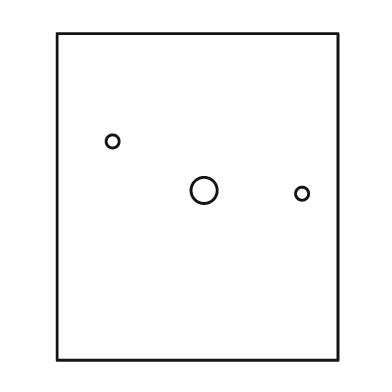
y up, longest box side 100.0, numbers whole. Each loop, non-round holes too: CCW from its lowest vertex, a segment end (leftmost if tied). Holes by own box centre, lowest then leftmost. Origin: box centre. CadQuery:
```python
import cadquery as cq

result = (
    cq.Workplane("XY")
    .moveTo(-43.0, -50.0)
    .lineTo(43.0, -50.0)
    .lineTo(43.0, 50.0)
    .lineTo(-43.0, 50.0)
    .close()
    .moveTo(32.0, 1.0)
    .circle(2.0)
    .moveTo(2.0, 2.0)
    .circle(4.0)
    .moveTo(-26.0, 17.0)
    .circle(2.0)
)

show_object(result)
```